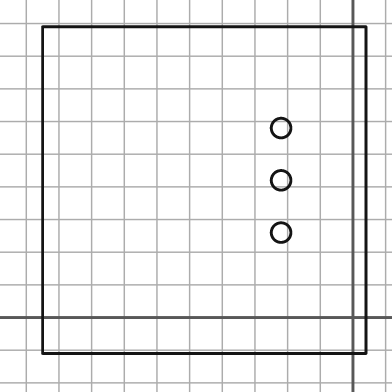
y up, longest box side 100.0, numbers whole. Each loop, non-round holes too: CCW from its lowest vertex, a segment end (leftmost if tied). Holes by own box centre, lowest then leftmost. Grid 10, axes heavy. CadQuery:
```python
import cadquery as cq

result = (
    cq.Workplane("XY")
    .moveTo(-95.0, -11.0)
    .lineTo(4.0, -11.0)
    .lineTo(4.0, 89.0)
    .lineTo(-95.0, 89.0)
    .close()
    .moveTo(-22.0, 26.0)
    .circle(3.0)
    .moveTo(-22.0, 42.0)
    .circle(3.0)
    .moveTo(-22.0, 58.0)
    .circle(3.0)
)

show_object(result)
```